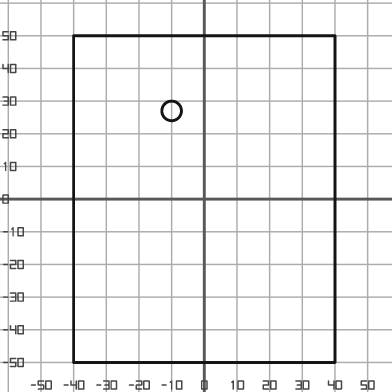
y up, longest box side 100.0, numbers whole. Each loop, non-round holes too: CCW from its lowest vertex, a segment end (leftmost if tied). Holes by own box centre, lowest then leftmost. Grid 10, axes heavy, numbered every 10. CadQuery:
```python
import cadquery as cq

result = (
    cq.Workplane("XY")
    .moveTo(-40.0, -50.0)
    .lineTo(40.0, -50.0)
    .lineTo(40.0, 50.0)
    .lineTo(-40.0, 50.0)
    .close()
    .moveTo(-10.0, 27.0)
    .circle(3.0)
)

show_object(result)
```